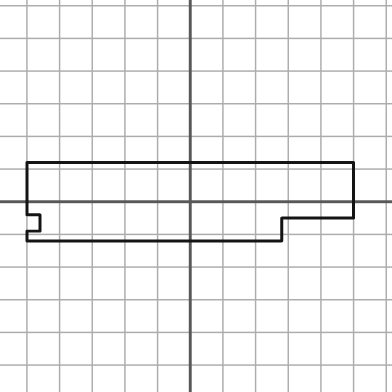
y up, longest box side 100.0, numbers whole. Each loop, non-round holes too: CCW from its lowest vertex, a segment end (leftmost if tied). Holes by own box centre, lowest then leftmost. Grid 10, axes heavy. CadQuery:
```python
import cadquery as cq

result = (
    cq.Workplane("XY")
    .moveTo(-50.0, -12.0)
    .lineTo(28.0, -12.0)
    .lineTo(28.0, -5.0)
    .lineTo(50.0, -5.0)
    .lineTo(50.0, 12.0)
    .lineTo(-50.0, 12.0)
    .lineTo(-50.0, -4.0)
    .lineTo(-46.0, -4.0)
    .lineTo(-46.0, -9.0)
    .lineTo(-50.0, -9.0)
    .close()
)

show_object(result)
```